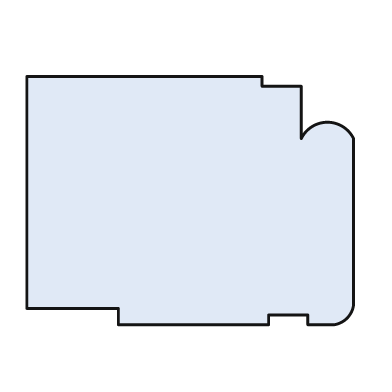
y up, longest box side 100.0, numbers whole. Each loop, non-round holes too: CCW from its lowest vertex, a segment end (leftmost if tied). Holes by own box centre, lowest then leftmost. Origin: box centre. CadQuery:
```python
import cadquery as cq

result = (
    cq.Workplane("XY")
    .moveTo(-22.0, -38.0)
    .lineTo(24.0, -38.0)
    .lineTo(24.0, -35.0)
    .lineTo(36.0, -35.0)
    .lineTo(36.0, -38.0)
    .lineTo(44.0, -38.0)
    .threePointArc((48.0, -36.0), (50.0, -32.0))
    .lineTo(50.0, 19.0)
    .threePointArc((42.0, 24.0), (34.0, 19.0))
    .lineTo(34.0, 35.0)
    .lineTo(22.0, 35.0)
    .lineTo(22.0, 38.0)
    .lineTo(-50.0, 38.0)
    .lineTo(-50.0, -33.0)
    .lineTo(-22.0, -33.0)
    .close()
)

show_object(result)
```